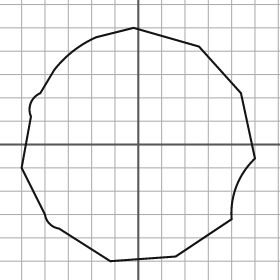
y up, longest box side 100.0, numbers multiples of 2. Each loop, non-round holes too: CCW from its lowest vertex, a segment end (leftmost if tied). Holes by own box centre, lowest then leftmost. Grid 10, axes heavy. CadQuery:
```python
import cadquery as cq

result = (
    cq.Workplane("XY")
    .moveTo(-12.0, -50.0)
    .lineTo(16.0, -48.0)
    .lineTo(40.0, -32.0)
    .threePointArc((42.0, -18.0), (50.0, -6.0))
    .lineTo(44.0, 22.0)
    .lineTo(26.0, 42.0)
    .lineTo(-2.0, 50.0)
    .lineTo(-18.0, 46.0)
    .threePointArc((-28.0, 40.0), (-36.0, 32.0))
    .lineTo(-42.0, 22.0)
    .threePointArc((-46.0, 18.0), (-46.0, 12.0))
    .lineTo(-50.0, -10.0)
    .lineTo(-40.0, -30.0)
    .threePointArc((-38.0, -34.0), (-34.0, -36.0))
    .close()
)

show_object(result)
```